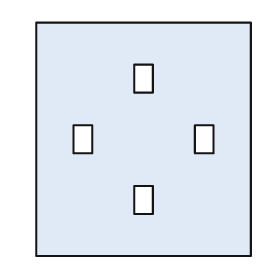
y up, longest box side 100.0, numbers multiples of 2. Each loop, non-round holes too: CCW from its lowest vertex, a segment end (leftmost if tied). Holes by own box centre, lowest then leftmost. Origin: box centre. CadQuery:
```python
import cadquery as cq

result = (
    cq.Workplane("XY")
    .moveTo(-46.0, -50.0)
    .lineTo(46.0, -50.0)
    .lineTo(46.0, 50.0)
    .lineTo(-46.0, 50.0)
    .close()
    .moveTo(-4.0, -32.0)
    .lineTo(4.0, -32.0)
    .lineTo(4.0, -20.0)
    .lineTo(-4.0, -20.0)
    .close()
    .moveTo(-30.0, -6.0)
    .lineTo(-22.0, -6.0)
    .lineTo(-22.0, 6.0)
    .lineTo(-30.0, 6.0)
    .close()
    .moveTo(22.0, -6.0)
    .lineTo(30.0, -6.0)
    .lineTo(30.0, 6.0)
    .lineTo(22.0, 6.0)
    .close()
    .moveTo(-4.0, 20.0)
    .lineTo(4.0, 20.0)
    .lineTo(4.0, 32.0)
    .lineTo(-4.0, 32.0)
    .close()
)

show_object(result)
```